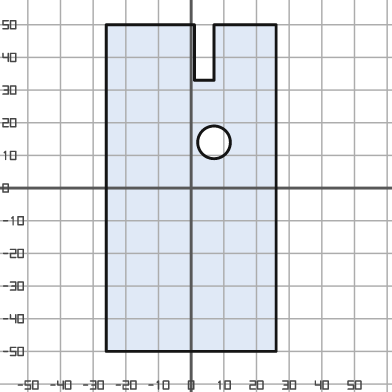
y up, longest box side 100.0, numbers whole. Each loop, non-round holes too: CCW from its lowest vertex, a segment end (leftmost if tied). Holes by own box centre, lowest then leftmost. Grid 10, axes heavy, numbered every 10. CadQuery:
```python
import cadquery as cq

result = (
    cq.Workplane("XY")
    .moveTo(-26.0, -50.0)
    .lineTo(26.0, -50.0)
    .lineTo(26.0, 50.0)
    .lineTo(7.0, 50.0)
    .lineTo(7.0, 33.0)
    .lineTo(1.0, 33.0)
    .lineTo(1.0, 50.0)
    .lineTo(-26.0, 50.0)
    .close()
    .moveTo(7.0, 14.0)
    .circle(5.0)
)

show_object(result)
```